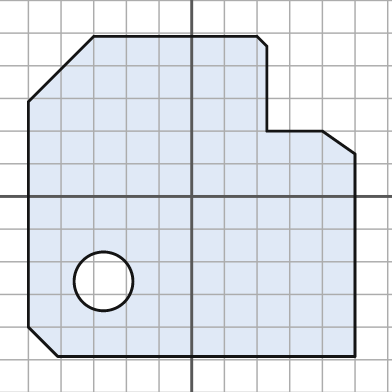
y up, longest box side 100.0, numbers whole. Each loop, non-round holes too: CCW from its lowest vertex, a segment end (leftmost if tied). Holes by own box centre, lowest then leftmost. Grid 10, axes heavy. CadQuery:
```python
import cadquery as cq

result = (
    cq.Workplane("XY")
    .moveTo(-41.0, -49.0)
    .lineTo(50.0, -49.0)
    .lineTo(50.0, 13.0)
    .lineTo(40.0, 20.0)
    .lineTo(23.0, 20.0)
    .lineTo(23.0, 46.0)
    .lineTo(20.0, 49.0)
    .lineTo(-30.0, 49.0)
    .lineTo(-50.0, 29.0)
    .lineTo(-50.0, -40.0)
    .close()
    .moveTo(-27.0, -26.0)
    .circle(9.0)
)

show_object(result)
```